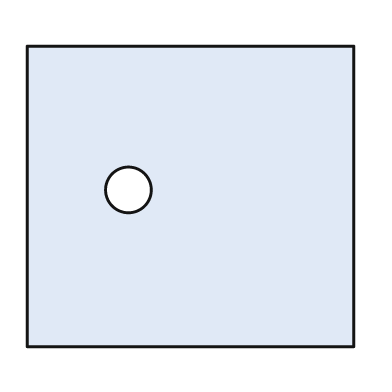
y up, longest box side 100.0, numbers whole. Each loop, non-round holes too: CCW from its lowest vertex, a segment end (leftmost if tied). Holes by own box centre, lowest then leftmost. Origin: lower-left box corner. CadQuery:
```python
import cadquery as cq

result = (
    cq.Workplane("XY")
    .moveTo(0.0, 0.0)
    .lineTo(100.0, 0.0)
    .lineTo(100.0, 92.0)
    .lineTo(0.0, 92.0)
    .close()
    .moveTo(31.0, 48.0)
    .circle(7.0)
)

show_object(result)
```